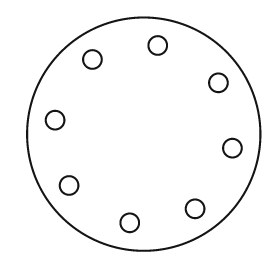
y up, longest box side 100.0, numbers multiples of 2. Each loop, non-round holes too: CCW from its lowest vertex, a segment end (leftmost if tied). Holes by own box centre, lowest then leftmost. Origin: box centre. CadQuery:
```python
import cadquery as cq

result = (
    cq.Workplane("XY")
    .moveTo(0.0, 0.0)
    .circle(50.0)
    .moveTo(-6.0, -38.0)
    .circle(4.0)
    .moveTo(22.0, -32.0)
    .circle(4.0)
    .moveTo(-32.0, -22.0)
    .circle(4.0)
    .moveTo(38.0, -6.0)
    .circle(4.0)
    .moveTo(-38.0, 6.0)
    .circle(4.0)
    .moveTo(32.0, 22.0)
    .circle(4.0)
    .moveTo(-22.0, 32.0)
    .circle(4.0)
    .moveTo(6.0, 38.0)
    .circle(4.0)
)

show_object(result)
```